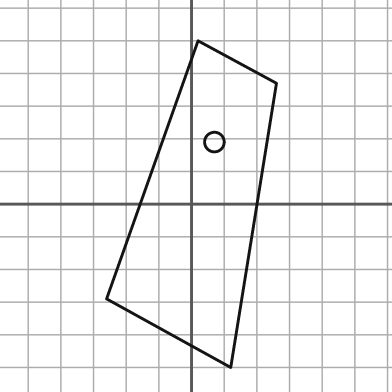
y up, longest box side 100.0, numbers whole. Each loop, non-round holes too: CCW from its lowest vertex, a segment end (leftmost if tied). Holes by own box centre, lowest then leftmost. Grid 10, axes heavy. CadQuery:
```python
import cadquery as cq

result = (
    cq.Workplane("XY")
    .moveTo(12.0, -50.0)
    .lineTo(26.0, 37.0)
    .lineTo(2.0, 50.0)
    .lineTo(-26.0, -29.0)
    .close()
    .moveTo(7.0, 19.0)
    .circle(3.0)
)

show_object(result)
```